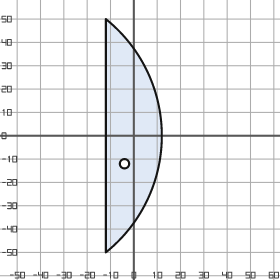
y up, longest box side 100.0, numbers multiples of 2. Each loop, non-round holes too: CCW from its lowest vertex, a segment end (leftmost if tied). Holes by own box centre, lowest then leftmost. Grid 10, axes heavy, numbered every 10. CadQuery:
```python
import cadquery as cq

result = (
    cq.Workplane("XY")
    .moveTo(-12.0, -50.0)
    .threePointArc((12.0, 0.0), (-12.0, 50.0))
    .close()
    .moveTo(-4.0, -12.0)
    .circle(2.0)
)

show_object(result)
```